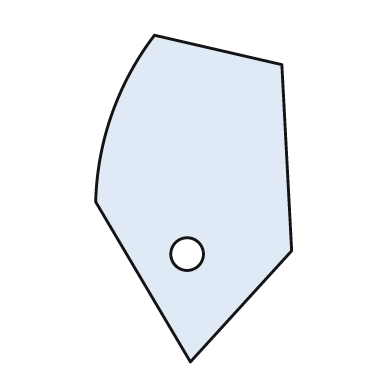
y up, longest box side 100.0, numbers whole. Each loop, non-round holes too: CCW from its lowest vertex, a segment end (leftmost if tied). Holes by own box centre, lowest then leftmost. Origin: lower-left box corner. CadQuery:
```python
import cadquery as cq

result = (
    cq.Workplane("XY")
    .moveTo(29.0, 0.0)
    .lineTo(60.0, 34.0)
    .lineTo(57.0, 91.0)
    .lineTo(18.0, 100.0)
    .threePointArc((5.0, 76.0), (0.0, 49.0))
    .close()
    .moveTo(28.0, 33.0)
    .circle(5.0)
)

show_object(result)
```